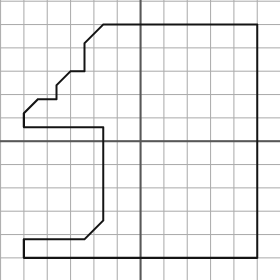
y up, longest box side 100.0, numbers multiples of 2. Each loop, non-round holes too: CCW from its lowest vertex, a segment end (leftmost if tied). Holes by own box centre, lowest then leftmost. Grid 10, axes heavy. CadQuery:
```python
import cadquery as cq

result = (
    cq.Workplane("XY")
    .moveTo(-50.0, -50.0)
    .lineTo(50.0, -50.0)
    .lineTo(50.0, 50.0)
    .lineTo(-16.0, 50.0)
    .lineTo(-24.0, 42.0)
    .lineTo(-24.0, 30.0)
    .lineTo(-30.0, 30.0)
    .lineTo(-36.0, 24.0)
    .lineTo(-36.0, 18.0)
    .lineTo(-44.0, 18.0)
    .lineTo(-50.0, 12.0)
    .lineTo(-50.0, 6.0)
    .lineTo(-16.0, 6.0)
    .lineTo(-16.0, -34.0)
    .lineTo(-24.0, -42.0)
    .lineTo(-50.0, -42.0)
    .close()
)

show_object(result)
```